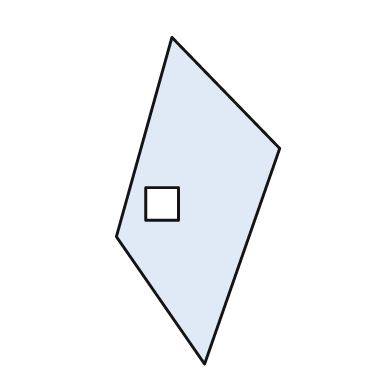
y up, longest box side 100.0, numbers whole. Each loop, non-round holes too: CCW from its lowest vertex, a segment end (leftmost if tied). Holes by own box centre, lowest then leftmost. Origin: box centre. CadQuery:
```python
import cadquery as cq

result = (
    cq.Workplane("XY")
    .moveTo(2.0, -50.0)
    .lineTo(25.0, 16.0)
    .lineTo(-8.0, 50.0)
    .lineTo(-25.0, -11.0)
    .close()
    .moveTo(-16.0, -6.0)
    .lineTo(-6.0, -6.0)
    .lineTo(-6.0, 4.0)
    .lineTo(-16.0, 4.0)
    .close()
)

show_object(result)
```